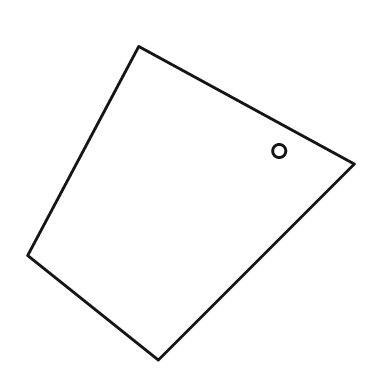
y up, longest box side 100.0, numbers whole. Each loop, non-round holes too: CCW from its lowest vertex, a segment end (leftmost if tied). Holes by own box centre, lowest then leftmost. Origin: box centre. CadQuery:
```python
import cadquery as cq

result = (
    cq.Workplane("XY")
    .moveTo(-10.0, -48.0)
    .lineTo(50.0, 12.0)
    .lineTo(-16.0, 48.0)
    .lineTo(-50.0, -16.0)
    .close()
    .moveTo(27.0, 16.0)
    .circle(2.0)
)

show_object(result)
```